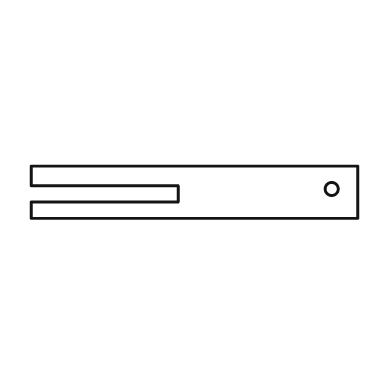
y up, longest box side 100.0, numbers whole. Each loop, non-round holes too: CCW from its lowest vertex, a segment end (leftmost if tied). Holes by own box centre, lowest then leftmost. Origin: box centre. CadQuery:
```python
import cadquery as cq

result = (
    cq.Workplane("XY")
    .moveTo(-50.0, -8.0)
    .lineTo(50.0, -8.0)
    .lineTo(50.0, 8.0)
    .lineTo(-50.0, 8.0)
    .lineTo(-50.0, 2.0)
    .lineTo(-5.0, 2.0)
    .lineTo(-5.0, -3.0)
    .lineTo(-50.0, -3.0)
    .close()
    .moveTo(42.0, 1.0)
    .circle(2.0)
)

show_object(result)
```